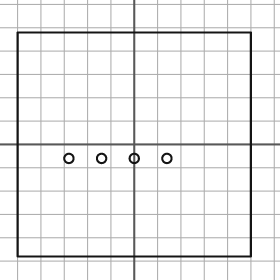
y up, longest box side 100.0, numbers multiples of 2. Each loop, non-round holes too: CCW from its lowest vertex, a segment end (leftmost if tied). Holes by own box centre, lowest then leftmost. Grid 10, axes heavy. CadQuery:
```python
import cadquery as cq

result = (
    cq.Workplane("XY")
    .moveTo(-50.0, -48.0)
    .lineTo(50.0, -48.0)
    .lineTo(50.0, 48.0)
    .lineTo(-50.0, 48.0)
    .close()
    .moveTo(-28.0, -6.0)
    .circle(2.0)
    .moveTo(-14.0, -6.0)
    .circle(2.0)
    .moveTo(0.0, -6.0)
    .circle(2.0)
    .moveTo(14.0, -6.0)
    .circle(2.0)
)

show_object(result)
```